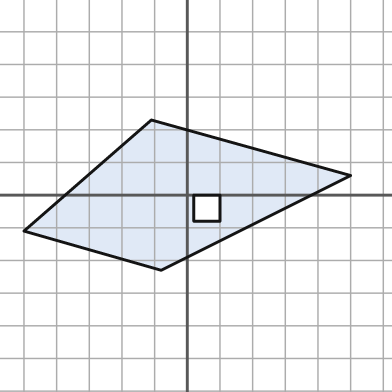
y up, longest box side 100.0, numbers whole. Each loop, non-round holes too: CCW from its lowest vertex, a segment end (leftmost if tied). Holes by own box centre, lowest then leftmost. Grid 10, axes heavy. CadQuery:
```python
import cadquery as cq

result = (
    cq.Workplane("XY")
    .moveTo(-8.0, -23.0)
    .lineTo(50.0, 6.0)
    .lineTo(-11.0, 23.0)
    .lineTo(-50.0, -11.0)
    .close()
    .moveTo(2.0, -8.0)
    .lineTo(10.0, -8.0)
    .lineTo(10.0, 0.0)
    .lineTo(2.0, 0.0)
    .close()
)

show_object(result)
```